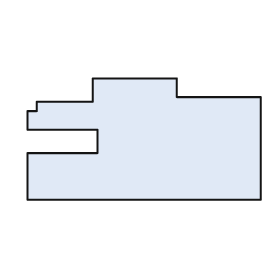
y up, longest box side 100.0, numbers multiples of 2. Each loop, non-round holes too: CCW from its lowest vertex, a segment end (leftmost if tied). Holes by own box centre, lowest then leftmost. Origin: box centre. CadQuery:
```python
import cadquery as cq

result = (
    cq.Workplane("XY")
    .moveTo(-50.0, -26.0)
    .lineTo(50.0, -26.0)
    .lineTo(50.0, 18.0)
    .lineTo(14.0, 18.0)
    .lineTo(14.0, 26.0)
    .lineTo(-22.0, 26.0)
    .lineTo(-22.0, 16.0)
    .lineTo(-46.0, 16.0)
    .lineTo(-46.0, 12.0)
    .lineTo(-50.0, 12.0)
    .lineTo(-50.0, 4.0)
    .lineTo(-20.0, 4.0)
    .lineTo(-20.0, -6.0)
    .lineTo(-50.0, -6.0)
    .close()
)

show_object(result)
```